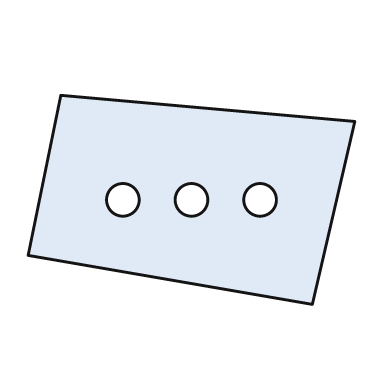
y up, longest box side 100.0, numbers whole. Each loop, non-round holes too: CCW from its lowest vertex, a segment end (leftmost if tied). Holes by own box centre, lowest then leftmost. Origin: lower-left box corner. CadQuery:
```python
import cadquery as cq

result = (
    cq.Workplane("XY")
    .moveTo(87.0, 0.0)
    .lineTo(100.0, 56.0)
    .lineTo(10.0, 64.0)
    .lineTo(0.0, 15.0)
    .close()
    .moveTo(29.0, 32.0)
    .circle(5.0)
    .moveTo(50.0, 32.0)
    .circle(5.0)
    .moveTo(71.0, 32.0)
    .circle(5.0)
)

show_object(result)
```